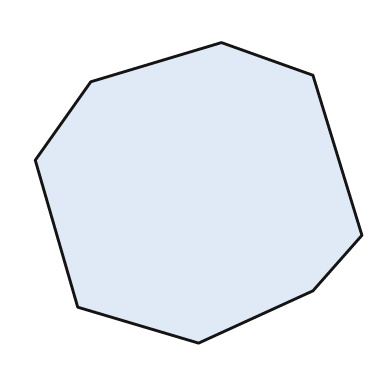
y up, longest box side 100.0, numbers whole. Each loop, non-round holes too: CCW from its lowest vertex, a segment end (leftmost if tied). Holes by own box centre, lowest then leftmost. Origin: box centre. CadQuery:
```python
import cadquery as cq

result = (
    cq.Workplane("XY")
    .moveTo(0.0, -46.0)
    .lineTo(35.0, -30.0)
    .lineTo(50.0, -13.0)
    .lineTo(35.0, 36.0)
    .lineTo(7.0, 46.0)
    .lineTo(-33.0, 34.0)
    .lineTo(-50.0, 10.0)
    .lineTo(-37.0, -35.0)
    .close()
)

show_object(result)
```